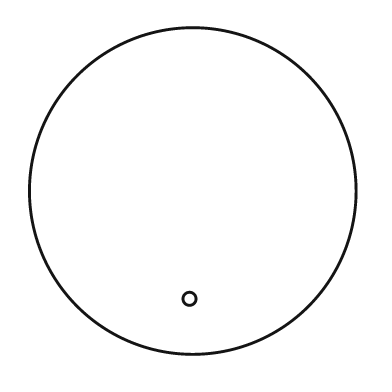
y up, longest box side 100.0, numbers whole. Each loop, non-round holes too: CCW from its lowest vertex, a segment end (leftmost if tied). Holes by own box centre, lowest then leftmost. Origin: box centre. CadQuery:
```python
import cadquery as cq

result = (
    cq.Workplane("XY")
    .moveTo(0.0, 0.0)
    .circle(50.0)
    .moveTo(-1.0, -33.0)
    .circle(2.0)
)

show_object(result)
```